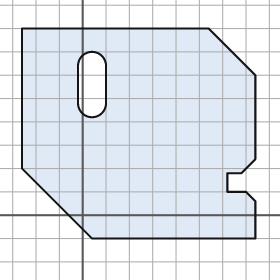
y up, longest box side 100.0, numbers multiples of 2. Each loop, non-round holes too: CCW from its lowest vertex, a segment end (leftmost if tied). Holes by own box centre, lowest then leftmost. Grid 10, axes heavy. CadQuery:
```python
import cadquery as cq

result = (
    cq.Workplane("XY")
    .moveTo(4.0, -10.0)
    .lineTo(74.0, -10.0)
    .lineTo(74.0, 6.0)
    .lineTo(70.0, 10.0)
    .lineTo(62.0, 10.0)
    .lineTo(62.0, 18.0)
    .lineTo(68.0, 18.0)
    .lineTo(74.0, 24.0)
    .lineTo(74.0, 60.0)
    .lineTo(54.0, 80.0)
    .lineTo(-26.0, 80.0)
    .lineTo(-26.0, 20.0)
    .close()
    .moveTo(-2.0, 48.0)
    .threePointArc((4.0, 42.0), (10.0, 48.0))
    .lineTo(10.0, 64.0)
    .threePointArc((4.0, 70.0), (-2.0, 64.0))
    .close()
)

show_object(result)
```